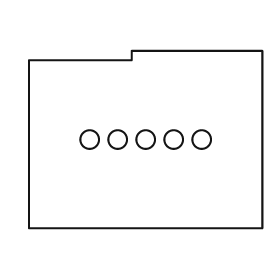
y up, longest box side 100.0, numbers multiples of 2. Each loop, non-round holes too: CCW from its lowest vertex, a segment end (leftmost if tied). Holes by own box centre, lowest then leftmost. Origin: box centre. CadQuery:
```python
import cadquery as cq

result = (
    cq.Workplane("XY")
    .moveTo(-50.0, -38.0)
    .lineTo(50.0, -38.0)
    .lineTo(50.0, 38.0)
    .lineTo(-6.0, 38.0)
    .lineTo(-6.0, 34.0)
    .lineTo(-50.0, 34.0)
    .close()
    .moveTo(-24.0, 0.0)
    .circle(4.0)
    .moveTo(-12.0, 0.0)
    .circle(4.0)
    .moveTo(0.0, 0.0)
    .circle(4.0)
    .moveTo(12.0, 0.0)
    .circle(4.0)
    .moveTo(24.0, 0.0)
    .circle(4.0)
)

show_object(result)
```